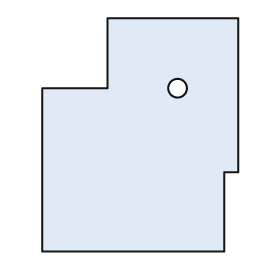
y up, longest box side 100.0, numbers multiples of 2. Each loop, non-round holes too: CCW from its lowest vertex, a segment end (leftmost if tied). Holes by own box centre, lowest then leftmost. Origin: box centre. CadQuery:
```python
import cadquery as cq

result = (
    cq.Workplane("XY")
    .moveTo(-42.0, -50.0)
    .lineTo(36.0, -50.0)
    .lineTo(36.0, -16.0)
    .lineTo(42.0, -16.0)
    .lineTo(42.0, 50.0)
    .lineTo(-14.0, 50.0)
    .lineTo(-14.0, 20.0)
    .lineTo(-42.0, 20.0)
    .close()
    .moveTo(16.0, 20.0)
    .circle(4.0)
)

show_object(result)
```